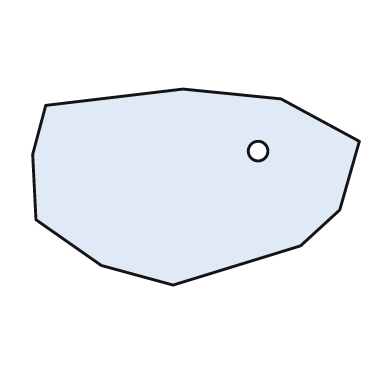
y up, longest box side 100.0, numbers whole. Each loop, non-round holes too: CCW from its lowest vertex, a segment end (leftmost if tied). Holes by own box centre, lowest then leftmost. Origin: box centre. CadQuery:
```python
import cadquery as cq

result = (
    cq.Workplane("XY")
    .moveTo(-7.0, -30.0)
    .lineTo(32.0, -18.0)
    .lineTo(44.0, -7.0)
    .lineTo(50.0, 14.0)
    .lineTo(26.0, 27.0)
    .lineTo(-4.0, 30.0)
    .lineTo(-46.0, 25.0)
    .lineTo(-50.0, 10.0)
    .lineTo(-49.0, -10.0)
    .lineTo(-29.0, -24.0)
    .close()
    .moveTo(19.0, 11.0)
    .circle(3.0)
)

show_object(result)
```